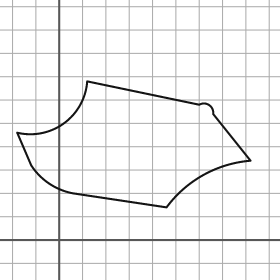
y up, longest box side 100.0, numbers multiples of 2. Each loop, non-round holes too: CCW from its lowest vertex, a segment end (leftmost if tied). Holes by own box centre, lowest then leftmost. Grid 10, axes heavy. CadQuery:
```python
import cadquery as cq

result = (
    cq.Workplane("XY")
    .moveTo(46.0, 14.0)
    .threePointArc((62.0, 28.0), (82.0, 34.0))
    .lineTo(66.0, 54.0)
    .threePointArc((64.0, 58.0), (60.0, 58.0))
    .lineTo(12.0, 68.0)
    .threePointArc((2.0, 50.0), (-18.0, 46.0))
    .lineTo(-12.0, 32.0)
    .threePointArc((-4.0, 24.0), (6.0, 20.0))
    .close()
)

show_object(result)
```